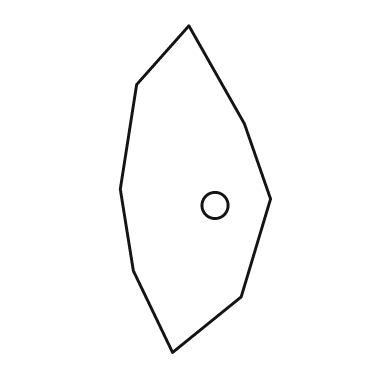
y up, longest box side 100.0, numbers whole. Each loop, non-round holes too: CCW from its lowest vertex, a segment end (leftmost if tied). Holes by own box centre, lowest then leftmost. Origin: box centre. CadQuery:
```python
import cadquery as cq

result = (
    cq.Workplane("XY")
    .moveTo(-7.0, -50.0)
    .lineTo(14.0, -33.0)
    .lineTo(23.0, -3.0)
    .lineTo(15.0, 20.0)
    .lineTo(-2.0, 50.0)
    .lineTo(-18.0, 32.0)
    .lineTo(-23.0, 0.0)
    .lineTo(-19.0, -25.0)
    .close()
    .moveTo(6.0, -5.0)
    .circle(4.0)
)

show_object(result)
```